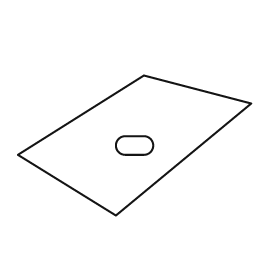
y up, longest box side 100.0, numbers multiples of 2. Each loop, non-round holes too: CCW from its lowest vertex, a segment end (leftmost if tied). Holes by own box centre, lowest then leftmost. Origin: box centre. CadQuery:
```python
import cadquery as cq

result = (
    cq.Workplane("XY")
    .moveTo(-8.0, -30.0)
    .lineTo(50.0, 18.0)
    .lineTo(4.0, 30.0)
    .lineTo(-50.0, -4.0)
    .close()
    .moveTo(-4.0, -4.0)
    .lineTo(4.0, -4.0)
    .threePointArc((8.0, 0.0), (4.0, 4.0))
    .lineTo(-4.0, 4.0)
    .threePointArc((-8.0, 0.0), (-4.0, -4.0))
    .close()
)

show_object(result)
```